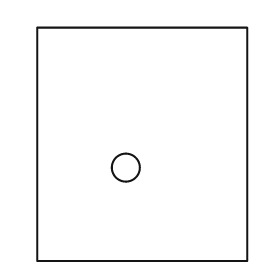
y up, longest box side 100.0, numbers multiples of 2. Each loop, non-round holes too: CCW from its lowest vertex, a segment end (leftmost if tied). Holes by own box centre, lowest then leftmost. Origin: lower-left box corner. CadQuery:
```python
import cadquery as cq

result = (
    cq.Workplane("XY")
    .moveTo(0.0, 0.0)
    .lineTo(90.0, 0.0)
    .lineTo(90.0, 100.0)
    .lineTo(0.0, 100.0)
    .close()
    .moveTo(38.0, 40.0)
    .circle(6.0)
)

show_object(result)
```